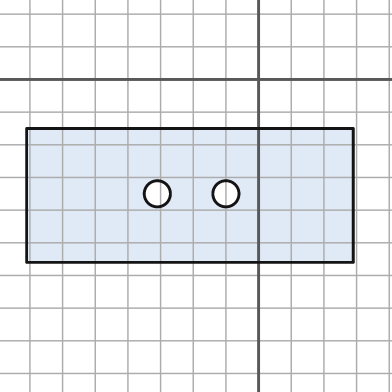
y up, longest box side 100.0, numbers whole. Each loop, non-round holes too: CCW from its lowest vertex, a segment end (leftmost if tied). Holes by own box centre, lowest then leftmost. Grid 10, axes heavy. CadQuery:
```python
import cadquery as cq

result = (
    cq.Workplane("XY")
    .moveTo(-71.0, -56.0)
    .lineTo(29.0, -56.0)
    .lineTo(29.0, -15.0)
    .lineTo(-71.0, -15.0)
    .close()
    .moveTo(-31.0, -35.0)
    .circle(4.0)
    .moveTo(-10.0, -35.0)
    .circle(4.0)
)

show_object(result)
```